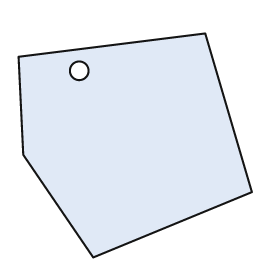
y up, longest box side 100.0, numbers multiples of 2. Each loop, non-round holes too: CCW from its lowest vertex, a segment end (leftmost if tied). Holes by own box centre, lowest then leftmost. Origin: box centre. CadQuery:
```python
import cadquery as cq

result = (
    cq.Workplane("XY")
    .moveTo(-18.0, -48.0)
    .lineTo(50.0, -20.0)
    .lineTo(30.0, 48.0)
    .lineTo(-50.0, 38.0)
    .lineTo(-48.0, -4.0)
    .close()
    .moveTo(-24.0, 32.0)
    .circle(4.0)
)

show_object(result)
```